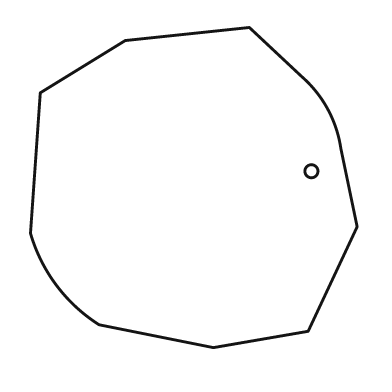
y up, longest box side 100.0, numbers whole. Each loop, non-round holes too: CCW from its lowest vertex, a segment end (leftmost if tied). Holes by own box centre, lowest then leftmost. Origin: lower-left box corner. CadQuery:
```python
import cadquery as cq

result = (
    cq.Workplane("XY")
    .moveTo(56.0, 0.0)
    .lineTo(85.0, 5.0)
    .lineTo(100.0, 37.0)
    .lineTo(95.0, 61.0)
    .threePointArc((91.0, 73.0), (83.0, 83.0))
    .lineTo(67.0, 98.0)
    .lineTo(29.0, 94.0)
    .lineTo(3.0, 78.0)
    .lineTo(0.0, 35.0)
    .threePointArc((8.0, 19.0), (21.0, 7.0))
    .close()
    .moveTo(86.0, 54.0)
    .circle(2.0)
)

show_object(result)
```